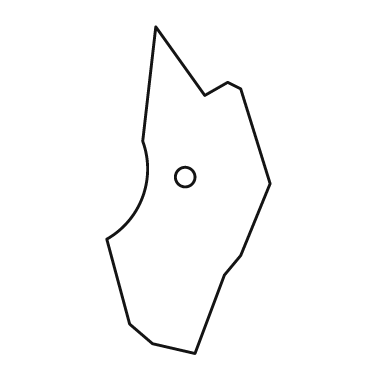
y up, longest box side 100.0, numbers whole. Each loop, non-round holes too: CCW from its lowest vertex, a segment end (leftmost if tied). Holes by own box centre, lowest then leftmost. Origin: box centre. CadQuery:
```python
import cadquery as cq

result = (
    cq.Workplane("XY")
    .moveTo(2.0, -50.0)
    .lineTo(11.0, -26.0)
    .lineTo(16.0, -20.0)
    .lineTo(25.0, 2.0)
    .lineTo(16.0, 31.0)
    .lineTo(12.0, 33.0)
    .lineTo(5.0, 29.0)
    .lineTo(-10.0, 50.0)
    .lineTo(-14.0, 15.0)
    .threePointArc((-14.0, -2.0), (-25.0, -15.0))
    .lineTo(-18.0, -41.0)
    .lineTo(-11.0, -47.0)
    .close()
    .moveTo(-1.0, 4.0)
    .circle(3.0)
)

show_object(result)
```